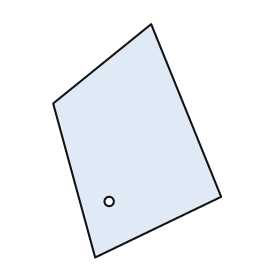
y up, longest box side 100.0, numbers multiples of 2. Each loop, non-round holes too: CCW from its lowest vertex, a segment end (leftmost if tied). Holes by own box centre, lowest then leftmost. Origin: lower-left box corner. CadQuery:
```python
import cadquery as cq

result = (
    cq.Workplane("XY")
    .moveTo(18.0, 0.0)
    .lineTo(72.0, 26.0)
    .lineTo(42.0, 100.0)
    .lineTo(0.0, 66.0)
    .close()
    .moveTo(24.0, 24.0)
    .circle(2.0)
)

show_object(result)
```